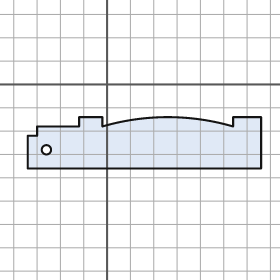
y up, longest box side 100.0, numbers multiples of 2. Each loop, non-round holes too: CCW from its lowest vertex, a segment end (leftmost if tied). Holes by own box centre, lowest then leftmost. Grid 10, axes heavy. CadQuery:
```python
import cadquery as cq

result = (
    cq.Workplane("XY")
    .moveTo(-34.0, -36.0)
    .lineTo(66.0, -36.0)
    .lineTo(66.0, -14.0)
    .lineTo(54.0, -14.0)
    .lineTo(54.0, -18.0)
    .threePointArc((26.0, -14.0), (-2.0, -18.0))
    .lineTo(-2.0, -14.0)
    .lineTo(-12.0, -14.0)
    .lineTo(-12.0, -18.0)
    .lineTo(-30.0, -18.0)
    .lineTo(-30.0, -22.0)
    .lineTo(-34.0, -22.0)
    .close()
    .moveTo(-26.0, -28.0)
    .circle(2.0)
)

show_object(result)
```